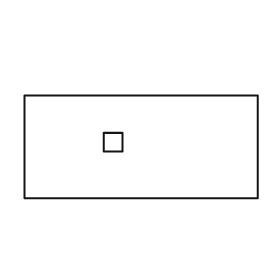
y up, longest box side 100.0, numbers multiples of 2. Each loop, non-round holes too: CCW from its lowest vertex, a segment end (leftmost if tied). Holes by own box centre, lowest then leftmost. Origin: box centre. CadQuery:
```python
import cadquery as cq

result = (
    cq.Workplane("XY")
    .moveTo(-50.0, -22.0)
    .lineTo(50.0, -22.0)
    .lineTo(50.0, 22.0)
    .lineTo(-50.0, 22.0)
    .close()
    .moveTo(-16.0, -2.0)
    .lineTo(-8.0, -2.0)
    .lineTo(-8.0, 6.0)
    .lineTo(-16.0, 6.0)
    .close()
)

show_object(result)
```